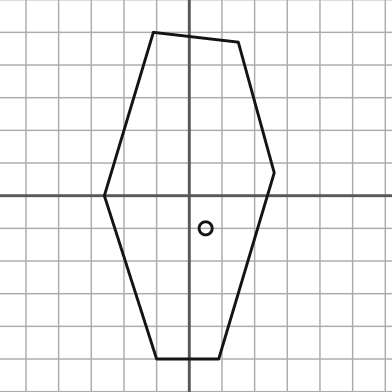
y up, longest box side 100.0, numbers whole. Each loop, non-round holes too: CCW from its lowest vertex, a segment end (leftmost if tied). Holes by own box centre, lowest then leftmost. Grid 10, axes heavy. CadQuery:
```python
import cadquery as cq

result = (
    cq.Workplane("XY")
    .moveTo(-10.0, -50.0)
    .lineTo(9.0, -50.0)
    .lineTo(26.0, 7.0)
    .lineTo(15.0, 47.0)
    .lineTo(-11.0, 50.0)
    .lineTo(-26.0, 0.0)
    .close()
    .moveTo(5.0, -10.0)
    .circle(2.0)
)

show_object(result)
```